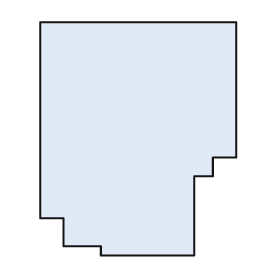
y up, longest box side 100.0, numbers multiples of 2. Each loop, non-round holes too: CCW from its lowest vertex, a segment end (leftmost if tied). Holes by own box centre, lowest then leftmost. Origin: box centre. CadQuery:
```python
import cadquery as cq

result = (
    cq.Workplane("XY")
    .moveTo(-16.0, -50.0)
    .lineTo(24.0, -50.0)
    .lineTo(24.0, -16.0)
    .lineTo(32.0, -16.0)
    .lineTo(32.0, -8.0)
    .lineTo(42.0, -8.0)
    .lineTo(42.0, 50.0)
    .lineTo(-42.0, 50.0)
    .lineTo(-42.0, -34.0)
    .lineTo(-32.0, -34.0)
    .lineTo(-32.0, -46.0)
    .lineTo(-16.0, -46.0)
    .close()
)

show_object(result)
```